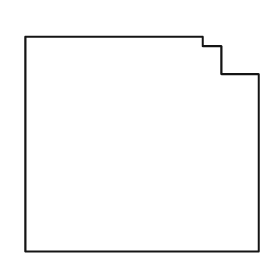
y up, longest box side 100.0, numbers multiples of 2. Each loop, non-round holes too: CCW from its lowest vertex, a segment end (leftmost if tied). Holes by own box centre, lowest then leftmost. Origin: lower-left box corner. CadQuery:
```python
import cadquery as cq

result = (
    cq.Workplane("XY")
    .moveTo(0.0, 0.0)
    .lineTo(100.0, 0.0)
    .lineTo(100.0, 76.0)
    .lineTo(84.0, 76.0)
    .lineTo(84.0, 88.0)
    .lineTo(76.0, 88.0)
    .lineTo(76.0, 92.0)
    .lineTo(0.0, 92.0)
    .close()
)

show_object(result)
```